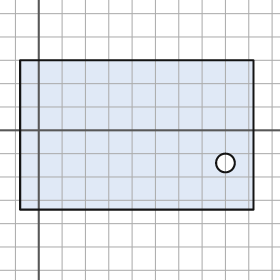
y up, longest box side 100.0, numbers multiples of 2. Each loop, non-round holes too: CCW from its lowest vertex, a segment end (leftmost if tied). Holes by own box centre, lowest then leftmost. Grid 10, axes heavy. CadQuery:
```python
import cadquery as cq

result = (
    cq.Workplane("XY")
    .moveTo(-8.0, -34.0)
    .lineTo(92.0, -34.0)
    .lineTo(92.0, 30.0)
    .lineTo(-8.0, 30.0)
    .close()
    .moveTo(80.0, -14.0)
    .circle(4.0)
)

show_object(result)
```